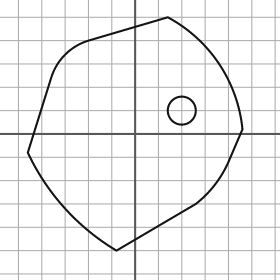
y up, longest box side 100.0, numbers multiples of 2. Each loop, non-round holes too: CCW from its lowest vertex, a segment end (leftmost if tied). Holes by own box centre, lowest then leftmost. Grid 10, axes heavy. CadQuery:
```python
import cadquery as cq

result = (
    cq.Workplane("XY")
    .moveTo(-8.0, -50.0)
    .lineTo(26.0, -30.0)
    .threePointArc((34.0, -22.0), (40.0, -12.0))
    .lineTo(46.0, 2.0)
    .threePointArc((36.0, 30.0), (14.0, 50.0))
    .lineTo(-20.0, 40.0)
    .threePointArc((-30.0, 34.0), (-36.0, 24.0))
    .lineTo(-46.0, -8.0)
    .threePointArc((-30.0, -32.0), (-8.0, -50.0))
    .close()
    .moveTo(20.0, 10.0)
    .circle(6.0)
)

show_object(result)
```